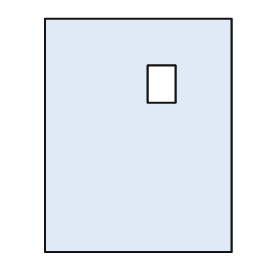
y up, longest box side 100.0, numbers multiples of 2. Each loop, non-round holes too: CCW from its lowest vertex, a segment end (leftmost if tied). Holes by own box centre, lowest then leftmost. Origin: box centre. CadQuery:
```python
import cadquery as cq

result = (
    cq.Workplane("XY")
    .moveTo(-40.0, -50.0)
    .lineTo(40.0, -50.0)
    .lineTo(40.0, 50.0)
    .lineTo(-40.0, 50.0)
    .close()
    .moveTo(4.0, 14.0)
    .lineTo(16.0, 14.0)
    .lineTo(16.0, 30.0)
    .lineTo(4.0, 30.0)
    .close()
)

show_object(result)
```